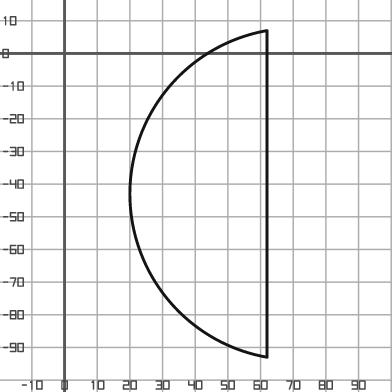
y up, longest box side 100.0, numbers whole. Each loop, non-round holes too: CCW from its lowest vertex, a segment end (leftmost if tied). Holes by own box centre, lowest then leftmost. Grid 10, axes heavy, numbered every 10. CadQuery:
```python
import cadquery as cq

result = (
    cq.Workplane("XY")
    .moveTo(62.0, -93.0)
    .lineTo(62.0, 7.0)
    .threePointArc((20.0, -43.0), (62.0, -93.0))
    .close()
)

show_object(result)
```